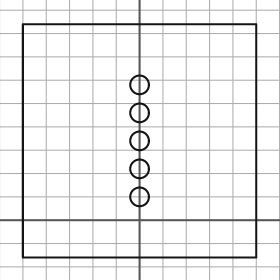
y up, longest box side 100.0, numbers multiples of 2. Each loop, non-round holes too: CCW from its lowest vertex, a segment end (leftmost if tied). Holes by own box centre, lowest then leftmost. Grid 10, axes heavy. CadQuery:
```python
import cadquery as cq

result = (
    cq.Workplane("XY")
    .moveTo(-50.0, -16.0)
    .lineTo(50.0, -16.0)
    .lineTo(50.0, 84.0)
    .lineTo(-50.0, 84.0)
    .close()
    .moveTo(0.0, 10.0)
    .circle(4.0)
    .moveTo(0.0, 22.0)
    .circle(4.0)
    .moveTo(0.0, 34.0)
    .circle(4.0)
    .moveTo(0.0, 46.0)
    .circle(4.0)
    .moveTo(0.0, 58.0)
    .circle(4.0)
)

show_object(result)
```